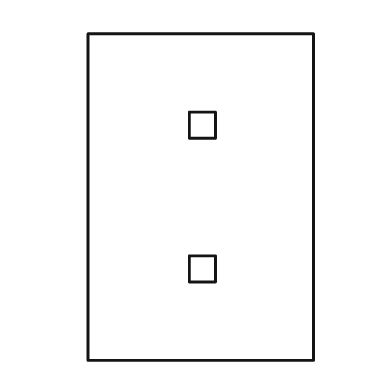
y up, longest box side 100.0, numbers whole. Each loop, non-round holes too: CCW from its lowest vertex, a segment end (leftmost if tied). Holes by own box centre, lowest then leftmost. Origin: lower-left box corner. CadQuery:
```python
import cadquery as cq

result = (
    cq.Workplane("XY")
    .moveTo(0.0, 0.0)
    .lineTo(69.0, 0.0)
    .lineTo(69.0, 100.0)
    .lineTo(0.0, 100.0)
    .close()
    .moveTo(31.0, 24.0)
    .lineTo(39.0, 24.0)
    .lineTo(39.0, 32.0)
    .lineTo(31.0, 32.0)
    .close()
    .moveTo(31.0, 68.0)
    .lineTo(39.0, 68.0)
    .lineTo(39.0, 76.0)
    .lineTo(31.0, 76.0)
    .close()
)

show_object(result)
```